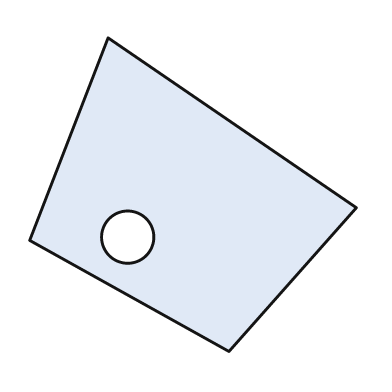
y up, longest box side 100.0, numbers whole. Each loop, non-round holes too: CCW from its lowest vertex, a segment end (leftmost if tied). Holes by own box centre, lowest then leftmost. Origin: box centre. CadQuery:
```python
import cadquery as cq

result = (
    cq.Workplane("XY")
    .moveTo(11.0, -48.0)
    .lineTo(50.0, -4.0)
    .lineTo(-26.0, 48.0)
    .lineTo(-50.0, -14.0)
    .close()
    .moveTo(-20.0, -13.0)
    .circle(8.0)
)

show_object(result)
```